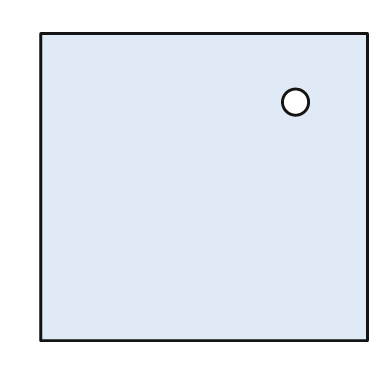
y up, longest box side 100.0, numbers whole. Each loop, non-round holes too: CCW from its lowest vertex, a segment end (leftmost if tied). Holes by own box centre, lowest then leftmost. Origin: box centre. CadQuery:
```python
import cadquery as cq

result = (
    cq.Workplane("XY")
    .moveTo(-50.0, -47.0)
    .lineTo(50.0, -47.0)
    .lineTo(50.0, 47.0)
    .lineTo(-50.0, 47.0)
    .close()
    .moveTo(28.0, 26.0)
    .circle(4.0)
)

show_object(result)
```